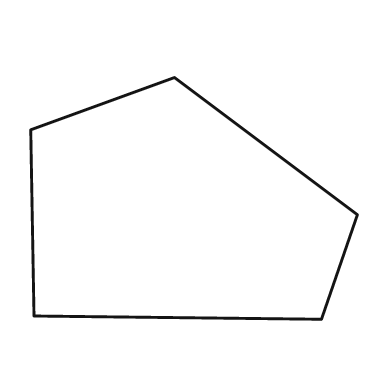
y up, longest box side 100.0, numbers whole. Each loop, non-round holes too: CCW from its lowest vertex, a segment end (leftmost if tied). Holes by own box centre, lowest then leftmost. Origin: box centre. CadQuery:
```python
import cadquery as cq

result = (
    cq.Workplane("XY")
    .moveTo(39.0, -37.0)
    .lineTo(50.0, -5.0)
    .lineTo(-6.0, 37.0)
    .lineTo(-50.0, 21.0)
    .lineTo(-49.0, -36.0)
    .close()
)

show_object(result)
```